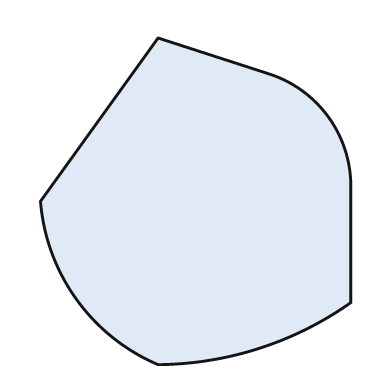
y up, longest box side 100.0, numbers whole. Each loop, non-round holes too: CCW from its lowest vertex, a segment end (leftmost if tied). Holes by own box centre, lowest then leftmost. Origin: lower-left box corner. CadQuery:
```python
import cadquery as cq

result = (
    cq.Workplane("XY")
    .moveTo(36.0, 0.0)
    .threePointArc((67.0, 5.0), (95.0, 19.0))
    .lineTo(95.0, 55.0)
    .threePointArc((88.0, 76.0), (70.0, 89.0))
    .lineTo(36.0, 100.0)
    .lineTo(0.0, 50.0)
    .threePointArc((11.0, 20.0), (36.0, 0.0))
    .close()
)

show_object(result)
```